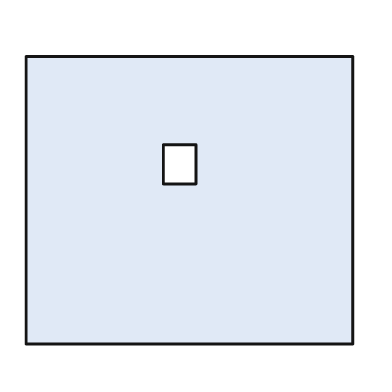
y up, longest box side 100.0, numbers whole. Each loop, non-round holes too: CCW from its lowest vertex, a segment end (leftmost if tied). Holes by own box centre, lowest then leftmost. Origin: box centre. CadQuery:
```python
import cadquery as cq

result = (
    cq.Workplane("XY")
    .moveTo(-50.0, -44.0)
    .lineTo(50.0, -44.0)
    .lineTo(50.0, 44.0)
    .lineTo(-50.0, 44.0)
    .close()
    .moveTo(-8.0, 5.0)
    .lineTo(2.0, 5.0)
    .lineTo(2.0, 17.0)
    .lineTo(-8.0, 17.0)
    .close()
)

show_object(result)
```